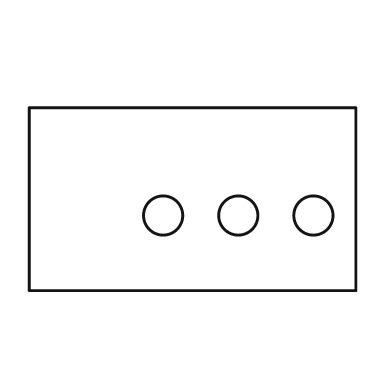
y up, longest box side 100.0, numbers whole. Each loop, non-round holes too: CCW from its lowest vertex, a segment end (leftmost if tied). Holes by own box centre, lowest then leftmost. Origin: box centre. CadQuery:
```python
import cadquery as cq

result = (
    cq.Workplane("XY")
    .moveTo(-50.0, -28.0)
    .lineTo(50.0, -28.0)
    .lineTo(50.0, 28.0)
    .lineTo(-50.0, 28.0)
    .close()
    .moveTo(-9.0, -5.0)
    .circle(6.0)
    .moveTo(14.0, -5.0)
    .circle(6.0)
    .moveTo(37.0, -5.0)
    .circle(6.0)
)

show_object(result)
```